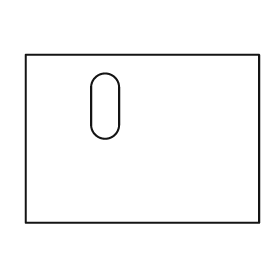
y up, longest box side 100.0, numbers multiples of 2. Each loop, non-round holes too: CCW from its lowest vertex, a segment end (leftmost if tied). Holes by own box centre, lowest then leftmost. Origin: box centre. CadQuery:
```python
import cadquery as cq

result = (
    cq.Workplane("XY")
    .moveTo(-50.0, -36.0)
    .lineTo(50.0, -36.0)
    .lineTo(50.0, 36.0)
    .lineTo(-50.0, 36.0)
    .close()
    .moveTo(-22.0, 6.0)
    .threePointArc((-16.0, 0.0), (-10.0, 6.0))
    .lineTo(-10.0, 22.0)
    .threePointArc((-16.0, 28.0), (-22.0, 22.0))
    .close()
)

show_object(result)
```